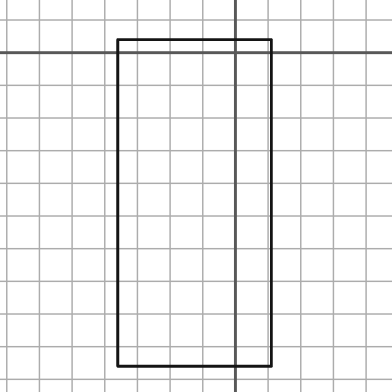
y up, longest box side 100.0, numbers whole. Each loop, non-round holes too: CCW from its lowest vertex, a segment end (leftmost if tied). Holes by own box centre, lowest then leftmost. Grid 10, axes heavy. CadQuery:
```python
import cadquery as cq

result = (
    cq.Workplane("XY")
    .moveTo(-36.0, -96.0)
    .lineTo(11.0, -96.0)
    .lineTo(11.0, 4.0)
    .lineTo(-36.0, 4.0)
    .close()
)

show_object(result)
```